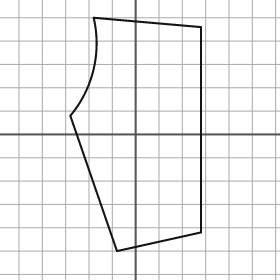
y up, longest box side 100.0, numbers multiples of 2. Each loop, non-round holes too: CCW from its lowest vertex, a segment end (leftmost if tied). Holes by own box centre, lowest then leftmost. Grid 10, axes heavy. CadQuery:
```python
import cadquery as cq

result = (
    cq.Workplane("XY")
    .moveTo(-8.0, -50.0)
    .lineTo(28.0, -42.0)
    .lineTo(28.0, 46.0)
    .lineTo(-18.0, 50.0)
    .threePointArc((-18.0, 28.0), (-28.0, 8.0))
    .close()
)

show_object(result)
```